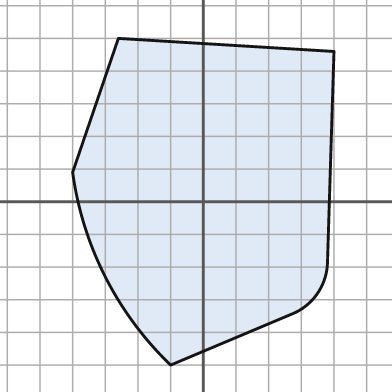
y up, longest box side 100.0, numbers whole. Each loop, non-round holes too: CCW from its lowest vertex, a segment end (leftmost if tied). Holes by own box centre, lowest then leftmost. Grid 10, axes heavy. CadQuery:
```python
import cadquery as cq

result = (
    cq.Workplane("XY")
    .moveTo(-10.0, -50.0)
    .lineTo(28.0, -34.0)
    .threePointArc((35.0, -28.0), (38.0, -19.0))
    .lineTo(40.0, 46.0)
    .lineTo(-26.0, 50.0)
    .lineTo(-40.0, 9.0)
    .threePointArc((-30.0, -23.0), (-10.0, -50.0))
    .close()
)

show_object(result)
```